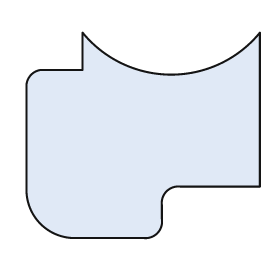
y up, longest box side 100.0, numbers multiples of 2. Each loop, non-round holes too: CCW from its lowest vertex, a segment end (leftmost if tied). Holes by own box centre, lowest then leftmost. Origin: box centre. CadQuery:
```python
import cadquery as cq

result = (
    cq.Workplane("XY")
    .moveTo(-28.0, -44.0)
    .lineTo(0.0, -44.0)
    .threePointArc((6.0, -42.0), (8.0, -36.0))
    .lineTo(8.0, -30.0)
    .threePointArc((10.0, -24.0), (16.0, -22.0))
    .lineTo(50.0, -22.0)
    .lineTo(50.0, 44.0)
    .threePointArc((12.0, 26.0), (-26.0, 44.0))
    .lineTo(-26.0, 28.0)
    .lineTo(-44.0, 28.0)
    .threePointArc((-48.0, 26.0), (-50.0, 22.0))
    .lineTo(-50.0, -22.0)
    .threePointArc((-44.0, -38.0), (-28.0, -44.0))
    .close()
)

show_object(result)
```